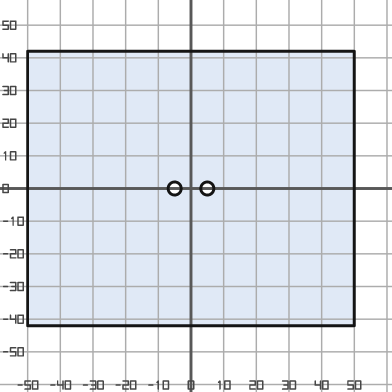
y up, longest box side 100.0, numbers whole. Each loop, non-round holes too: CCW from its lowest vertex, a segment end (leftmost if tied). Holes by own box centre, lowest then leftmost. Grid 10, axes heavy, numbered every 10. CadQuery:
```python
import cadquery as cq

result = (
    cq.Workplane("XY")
    .moveTo(-50.0, -42.0)
    .lineTo(50.0, -42.0)
    .lineTo(50.0, 42.0)
    .lineTo(-50.0, 42.0)
    .close()
    .moveTo(-5.0, 0.0)
    .circle(2.0)
    .moveTo(5.0, 0.0)
    .circle(2.0)
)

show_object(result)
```